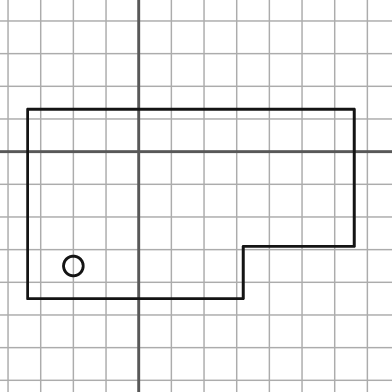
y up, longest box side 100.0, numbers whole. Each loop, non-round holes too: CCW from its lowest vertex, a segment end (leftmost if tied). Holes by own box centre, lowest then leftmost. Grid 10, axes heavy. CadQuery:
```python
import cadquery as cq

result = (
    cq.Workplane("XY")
    .moveTo(-34.0, -45.0)
    .lineTo(32.0, -45.0)
    .lineTo(32.0, -29.0)
    .lineTo(66.0, -29.0)
    .lineTo(66.0, 13.0)
    .lineTo(-34.0, 13.0)
    .close()
    .moveTo(-20.0, -35.0)
    .circle(3.0)
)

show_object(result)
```